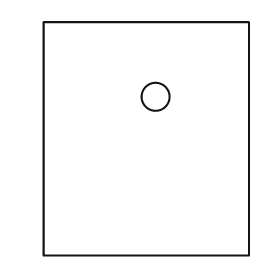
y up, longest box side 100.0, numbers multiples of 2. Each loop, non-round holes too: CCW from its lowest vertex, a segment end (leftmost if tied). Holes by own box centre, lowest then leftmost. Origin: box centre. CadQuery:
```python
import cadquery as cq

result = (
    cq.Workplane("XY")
    .moveTo(-44.0, -50.0)
    .lineTo(44.0, -50.0)
    .lineTo(44.0, 50.0)
    .lineTo(-44.0, 50.0)
    .close()
    .moveTo(4.0, 18.0)
    .circle(6.0)
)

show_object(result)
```